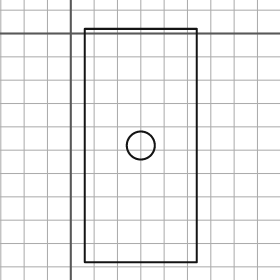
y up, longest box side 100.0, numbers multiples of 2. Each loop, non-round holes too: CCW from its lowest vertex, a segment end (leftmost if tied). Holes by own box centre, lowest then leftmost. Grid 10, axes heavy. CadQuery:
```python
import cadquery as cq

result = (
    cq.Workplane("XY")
    .moveTo(6.0, -98.0)
    .lineTo(54.0, -98.0)
    .lineTo(54.0, 2.0)
    .lineTo(6.0, 2.0)
    .close()
    .moveTo(30.0, -48.0)
    .circle(6.0)
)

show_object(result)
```